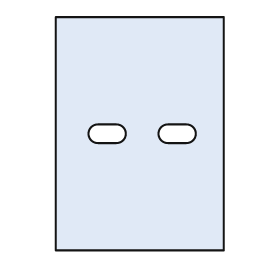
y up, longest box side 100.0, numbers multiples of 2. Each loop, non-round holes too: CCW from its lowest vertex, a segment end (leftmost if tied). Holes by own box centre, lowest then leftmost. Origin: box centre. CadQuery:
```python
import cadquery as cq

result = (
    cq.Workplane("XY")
    .moveTo(-36.0, -50.0)
    .lineTo(36.0, -50.0)
    .lineTo(36.0, 50.0)
    .lineTo(-36.0, 50.0)
    .close()
    .moveTo(-18.0, -4.0)
    .lineTo(-10.0, -4.0)
    .threePointArc((-6.0, 0.0), (-10.0, 4.0))
    .lineTo(-18.0, 4.0)
    .threePointArc((-22.0, 0.0), (-18.0, -4.0))
    .close()
    .moveTo(12.0, -4.0)
    .lineTo(20.0, -4.0)
    .threePointArc((24.0, 0.0), (20.0, 4.0))
    .lineTo(12.0, 4.0)
    .threePointArc((8.0, 0.0), (12.0, -4.0))
    .close()
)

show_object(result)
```